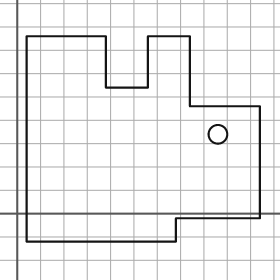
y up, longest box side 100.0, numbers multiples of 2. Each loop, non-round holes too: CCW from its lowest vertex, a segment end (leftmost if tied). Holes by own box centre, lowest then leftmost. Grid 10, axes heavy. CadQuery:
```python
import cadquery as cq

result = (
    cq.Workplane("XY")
    .moveTo(4.0, -12.0)
    .lineTo(68.0, -12.0)
    .lineTo(68.0, -2.0)
    .lineTo(104.0, -2.0)
    .lineTo(104.0, 46.0)
    .lineTo(74.0, 46.0)
    .lineTo(74.0, 76.0)
    .lineTo(56.0, 76.0)
    .lineTo(56.0, 54.0)
    .lineTo(38.0, 54.0)
    .lineTo(38.0, 76.0)
    .lineTo(4.0, 76.0)
    .close()
    .moveTo(86.0, 34.0)
    .circle(4.0)
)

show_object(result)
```